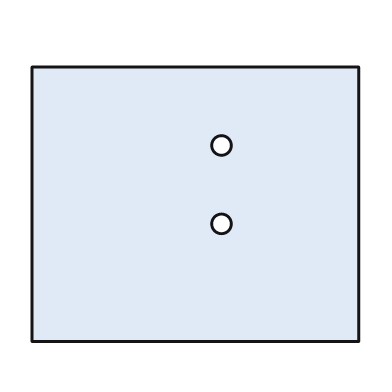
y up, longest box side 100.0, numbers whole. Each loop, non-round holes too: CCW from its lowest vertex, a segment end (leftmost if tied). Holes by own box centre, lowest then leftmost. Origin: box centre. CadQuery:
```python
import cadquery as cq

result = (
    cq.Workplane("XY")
    .moveTo(-50.0, -42.0)
    .lineTo(50.0, -42.0)
    .lineTo(50.0, 42.0)
    .lineTo(-50.0, 42.0)
    .close()
    .moveTo(8.0, -6.0)
    .circle(3.0)
    .moveTo(8.0, 18.0)
    .circle(3.0)
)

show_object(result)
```